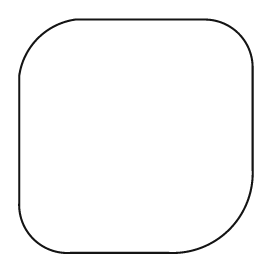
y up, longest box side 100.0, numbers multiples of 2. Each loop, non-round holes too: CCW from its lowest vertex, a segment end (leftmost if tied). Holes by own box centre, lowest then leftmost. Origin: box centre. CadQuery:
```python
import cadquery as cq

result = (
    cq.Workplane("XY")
    .moveTo(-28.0, -50.0)
    .lineTo(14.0, -50.0)
    .threePointArc((40.0, -40.0), (50.0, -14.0))
    .lineTo(50.0, 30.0)
    .threePointArc((44.0, 44.0), (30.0, 50.0))
    .lineTo(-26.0, 50.0)
    .threePointArc((-42.0, 42.0), (-50.0, 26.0))
    .lineTo(-50.0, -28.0)
    .threePointArc((-44.0, -44.0), (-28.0, -50.0))
    .close()
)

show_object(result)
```